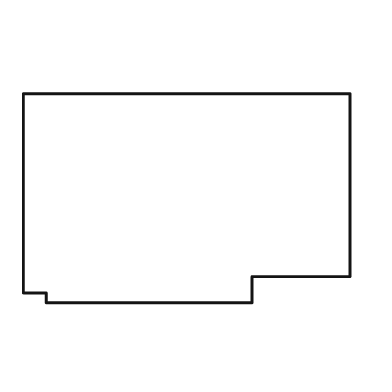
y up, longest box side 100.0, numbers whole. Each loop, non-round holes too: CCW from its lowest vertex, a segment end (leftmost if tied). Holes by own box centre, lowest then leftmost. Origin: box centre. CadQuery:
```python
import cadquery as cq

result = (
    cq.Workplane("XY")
    .moveTo(-43.0, -32.0)
    .lineTo(20.0, -32.0)
    .lineTo(20.0, -24.0)
    .lineTo(50.0, -24.0)
    .lineTo(50.0, 32.0)
    .lineTo(-50.0, 32.0)
    .lineTo(-50.0, -29.0)
    .lineTo(-43.0, -29.0)
    .close()
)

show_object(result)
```